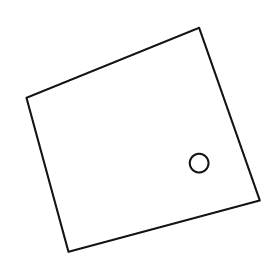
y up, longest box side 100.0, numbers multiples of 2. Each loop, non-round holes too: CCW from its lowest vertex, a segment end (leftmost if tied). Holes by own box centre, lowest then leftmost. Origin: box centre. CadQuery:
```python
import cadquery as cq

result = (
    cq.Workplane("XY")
    .moveTo(-32.0, -48.0)
    .lineTo(50.0, -26.0)
    .lineTo(24.0, 48.0)
    .lineTo(-50.0, 18.0)
    .close()
    .moveTo(24.0, -10.0)
    .circle(4.0)
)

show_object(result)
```